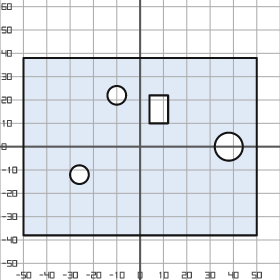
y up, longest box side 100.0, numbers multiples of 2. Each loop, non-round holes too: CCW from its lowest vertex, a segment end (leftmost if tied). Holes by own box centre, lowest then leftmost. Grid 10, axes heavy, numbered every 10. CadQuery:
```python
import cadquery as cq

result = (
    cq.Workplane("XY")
    .moveTo(-50.0, -38.0)
    .lineTo(50.0, -38.0)
    .lineTo(50.0, 38.0)
    .lineTo(-50.0, 38.0)
    .close()
    .moveTo(-26.0, -12.0)
    .circle(4.0)
    .moveTo(38.0, 0.0)
    .circle(6.0)
    .moveTo(4.0, 10.0)
    .lineTo(12.0, 10.0)
    .lineTo(12.0, 22.0)
    .lineTo(4.0, 22.0)
    .close()
    .moveTo(-10.0, 22.0)
    .circle(4.0)
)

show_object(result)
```